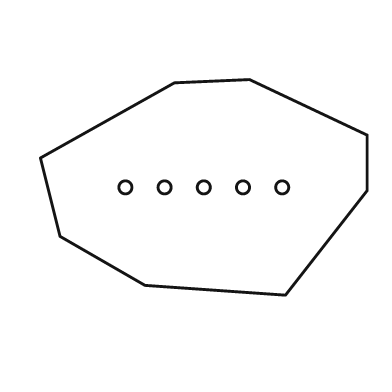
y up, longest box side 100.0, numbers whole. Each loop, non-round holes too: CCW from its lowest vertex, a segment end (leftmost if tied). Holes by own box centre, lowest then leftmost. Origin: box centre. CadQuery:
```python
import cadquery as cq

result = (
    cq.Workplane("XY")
    .moveTo(25.0, -33.0)
    .lineTo(50.0, -1.0)
    .lineTo(50.0, 16.0)
    .lineTo(14.0, 33.0)
    .lineTo(-9.0, 32.0)
    .lineTo(-50.0, 9.0)
    .lineTo(-44.0, -15.0)
    .lineTo(-18.0, -30.0)
    .close()
    .moveTo(-24.0, 0.0)
    .circle(2.0)
    .moveTo(-12.0, 0.0)
    .circle(2.0)
    .moveTo(0.0, 0.0)
    .circle(2.0)
    .moveTo(12.0, 0.0)
    .circle(2.0)
    .moveTo(24.0, 0.0)
    .circle(2.0)
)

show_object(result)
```